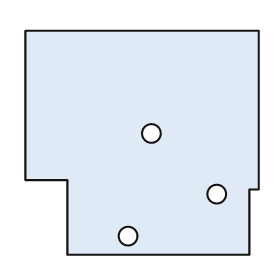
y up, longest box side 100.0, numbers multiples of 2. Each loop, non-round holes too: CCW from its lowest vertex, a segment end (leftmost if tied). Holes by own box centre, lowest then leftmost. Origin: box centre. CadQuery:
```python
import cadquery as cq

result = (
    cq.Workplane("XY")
    .moveTo(-32.0, -48.0)
    .lineTo(46.0, -48.0)
    .lineTo(46.0, -20.0)
    .lineTo(50.0, -20.0)
    .lineTo(50.0, 48.0)
    .lineTo(-50.0, 48.0)
    .lineTo(-50.0, -16.0)
    .lineTo(-32.0, -16.0)
    .close()
    .moveTo(-6.0, -40.0)
    .circle(4.0)
    .moveTo(32.0, -22.0)
    .circle(4.0)
    .moveTo(4.0, 4.0)
    .circle(4.0)
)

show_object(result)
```